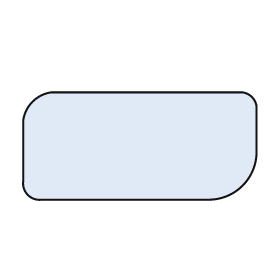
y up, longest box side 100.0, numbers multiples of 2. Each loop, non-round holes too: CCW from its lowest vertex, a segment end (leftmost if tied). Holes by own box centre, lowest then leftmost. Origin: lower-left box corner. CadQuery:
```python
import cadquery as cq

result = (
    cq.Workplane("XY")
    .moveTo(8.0, 0.0)
    .lineTo(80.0, 0.0)
    .threePointArc((94.0, 6.0), (100.0, 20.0))
    .lineTo(100.0, 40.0)
    .threePointArc((98.0, 44.0), (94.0, 46.0))
    .lineTo(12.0, 46.0)
    .threePointArc((4.0, 42.0), (0.0, 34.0))
    .lineTo(0.0, 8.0)
    .threePointArc((2.0, 2.0), (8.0, 0.0))
    .close()
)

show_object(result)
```